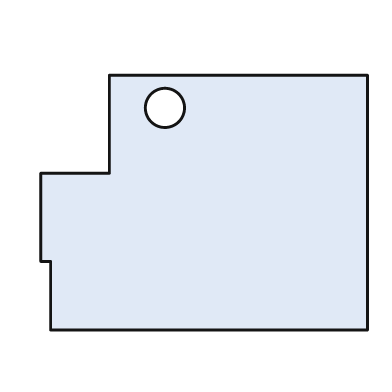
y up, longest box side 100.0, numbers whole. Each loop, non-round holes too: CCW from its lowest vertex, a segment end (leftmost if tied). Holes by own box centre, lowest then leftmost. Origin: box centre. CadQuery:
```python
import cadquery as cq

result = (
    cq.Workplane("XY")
    .moveTo(-47.0, -39.0)
    .lineTo(50.0, -39.0)
    .lineTo(50.0, 39.0)
    .lineTo(-29.0, 39.0)
    .lineTo(-29.0, 9.0)
    .lineTo(-50.0, 9.0)
    .lineTo(-50.0, -18.0)
    .lineTo(-47.0, -18.0)
    .close()
    .moveTo(-12.0, 29.0)
    .circle(6.0)
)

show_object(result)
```